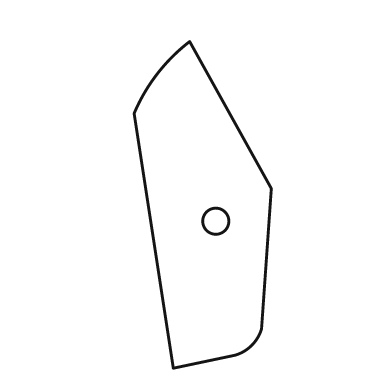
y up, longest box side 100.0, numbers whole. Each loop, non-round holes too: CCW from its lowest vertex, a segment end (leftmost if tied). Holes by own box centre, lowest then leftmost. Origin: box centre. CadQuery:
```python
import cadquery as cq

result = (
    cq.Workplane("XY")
    .moveTo(-9.0, -50.0)
    .lineTo(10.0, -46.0)
    .threePointArc((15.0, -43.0), (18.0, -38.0))
    .lineTo(21.0, 5.0)
    .lineTo(-4.0, 50.0)
    .threePointArc((-14.0, 40.0), (-21.0, 28.0))
    .close()
    .moveTo(4.0, -5.0)
    .circle(4.0)
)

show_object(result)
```